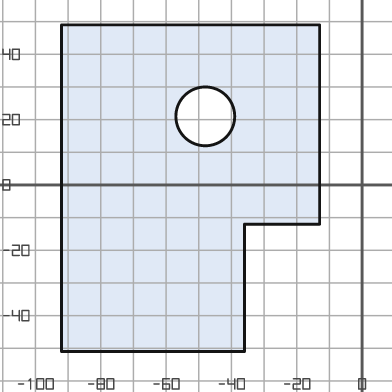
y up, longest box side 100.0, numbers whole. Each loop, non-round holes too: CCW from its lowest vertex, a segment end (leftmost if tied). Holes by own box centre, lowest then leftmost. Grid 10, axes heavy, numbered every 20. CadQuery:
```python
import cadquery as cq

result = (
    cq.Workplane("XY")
    .moveTo(-92.0, -51.0)
    .lineTo(-36.0, -51.0)
    .lineTo(-36.0, -12.0)
    .lineTo(-13.0, -12.0)
    .lineTo(-13.0, 49.0)
    .lineTo(-92.0, 49.0)
    .close()
    .moveTo(-48.0, 21.0)
    .circle(9.0)
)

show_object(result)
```